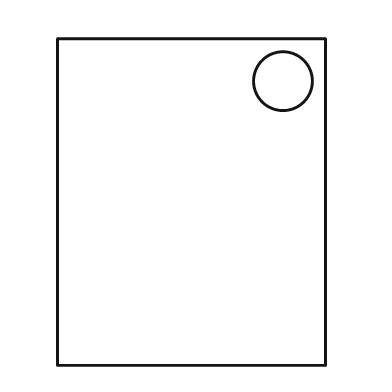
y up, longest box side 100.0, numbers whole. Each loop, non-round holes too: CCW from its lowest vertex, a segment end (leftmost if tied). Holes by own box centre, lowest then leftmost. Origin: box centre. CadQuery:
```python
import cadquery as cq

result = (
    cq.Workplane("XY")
    .moveTo(-41.0, -50.0)
    .lineTo(41.0, -50.0)
    .lineTo(41.0, 50.0)
    .lineTo(-41.0, 50.0)
    .close()
    .moveTo(28.0, 37.0)
    .circle(9.0)
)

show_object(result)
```